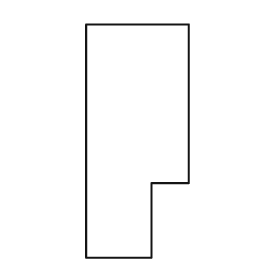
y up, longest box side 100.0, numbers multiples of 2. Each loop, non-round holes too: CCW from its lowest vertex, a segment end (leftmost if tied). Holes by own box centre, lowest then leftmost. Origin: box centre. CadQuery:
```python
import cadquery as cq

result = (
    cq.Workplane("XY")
    .moveTo(-22.0, -50.0)
    .lineTo(6.0, -50.0)
    .lineTo(6.0, -18.0)
    .lineTo(22.0, -18.0)
    .lineTo(22.0, 50.0)
    .lineTo(-22.0, 50.0)
    .close()
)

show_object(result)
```